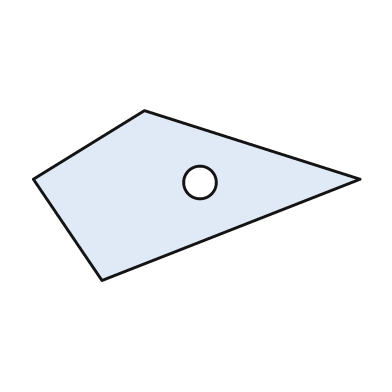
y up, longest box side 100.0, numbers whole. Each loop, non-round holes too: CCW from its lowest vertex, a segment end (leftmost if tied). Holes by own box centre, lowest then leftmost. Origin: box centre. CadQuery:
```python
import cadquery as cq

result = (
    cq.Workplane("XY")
    .moveTo(-29.0, -26.0)
    .lineTo(50.0, 5.0)
    .lineTo(-16.0, 26.0)
    .lineTo(-50.0, 5.0)
    .close()
    .moveTo(1.0, 4.0)
    .circle(5.0)
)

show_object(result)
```